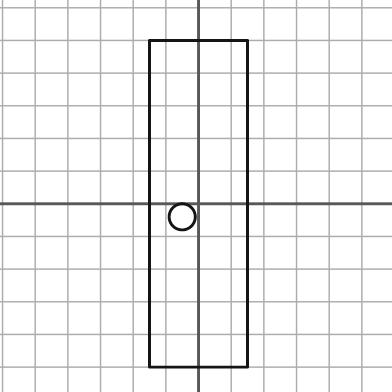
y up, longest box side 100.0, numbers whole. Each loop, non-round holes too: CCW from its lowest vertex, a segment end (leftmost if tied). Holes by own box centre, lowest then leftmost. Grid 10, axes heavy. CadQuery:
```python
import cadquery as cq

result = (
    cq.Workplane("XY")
    .moveTo(-15.0, -50.0)
    .lineTo(15.0, -50.0)
    .lineTo(15.0, 50.0)
    .lineTo(-15.0, 50.0)
    .close()
    .moveTo(-5.0, -4.0)
    .circle(4.0)
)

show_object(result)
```